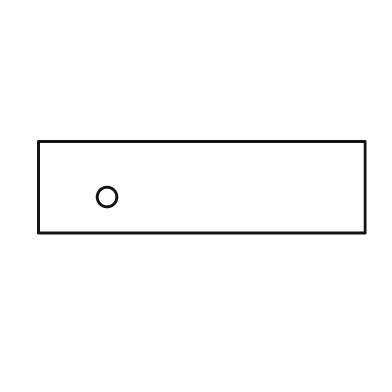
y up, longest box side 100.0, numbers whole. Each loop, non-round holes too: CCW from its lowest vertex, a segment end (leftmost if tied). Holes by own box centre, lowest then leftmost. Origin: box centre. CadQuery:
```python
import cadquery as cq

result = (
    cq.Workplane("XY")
    .moveTo(-50.0, -14.0)
    .lineTo(50.0, -14.0)
    .lineTo(50.0, 14.0)
    .lineTo(-50.0, 14.0)
    .close()
    .moveTo(-29.0, -3.0)
    .circle(3.0)
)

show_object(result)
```